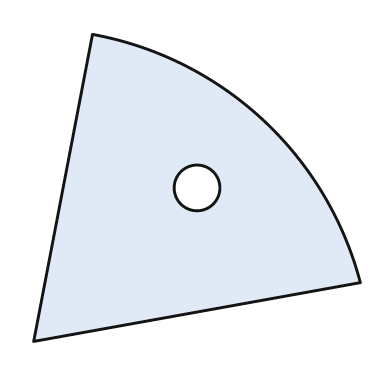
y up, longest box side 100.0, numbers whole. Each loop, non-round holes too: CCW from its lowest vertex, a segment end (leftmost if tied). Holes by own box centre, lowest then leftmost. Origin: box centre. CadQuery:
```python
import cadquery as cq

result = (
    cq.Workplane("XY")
    .moveTo(-50.0, -47.0)
    .lineTo(50.0, -29.0)
    .threePointArc((20.0, 21.0), (-32.0, 47.0))
    .close()
    .moveTo(0.0, 0.0)
    .circle(7.0)
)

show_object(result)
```